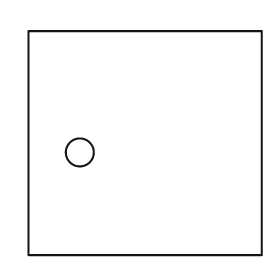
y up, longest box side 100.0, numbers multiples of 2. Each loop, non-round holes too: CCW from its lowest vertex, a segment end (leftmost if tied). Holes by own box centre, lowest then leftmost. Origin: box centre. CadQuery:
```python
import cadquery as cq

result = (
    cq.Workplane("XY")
    .moveTo(-50.0, -48.0)
    .lineTo(50.0, -48.0)
    .lineTo(50.0, 48.0)
    .lineTo(-50.0, 48.0)
    .close()
    .moveTo(-28.0, -4.0)
    .circle(6.0)
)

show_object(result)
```